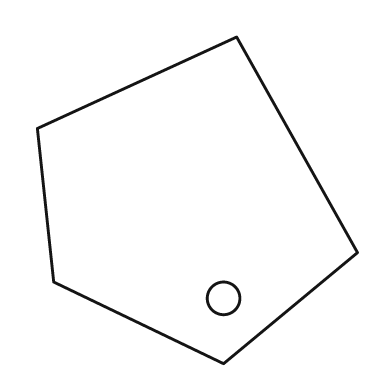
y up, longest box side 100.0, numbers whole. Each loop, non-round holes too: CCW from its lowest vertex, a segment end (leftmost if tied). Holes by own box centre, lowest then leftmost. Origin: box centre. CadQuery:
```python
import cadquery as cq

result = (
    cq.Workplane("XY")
    .moveTo(8.0, -50.0)
    .lineTo(49.0, -16.0)
    .lineTo(12.0, 50.0)
    .lineTo(-49.0, 22.0)
    .lineTo(-44.0, -25.0)
    .close()
    .moveTo(8.0, -30.0)
    .circle(5.0)
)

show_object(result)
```